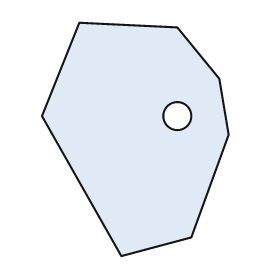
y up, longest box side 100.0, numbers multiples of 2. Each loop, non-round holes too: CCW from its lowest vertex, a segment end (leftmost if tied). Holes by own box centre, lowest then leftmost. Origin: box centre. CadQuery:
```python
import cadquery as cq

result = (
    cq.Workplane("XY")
    .moveTo(-6.0, -50.0)
    .lineTo(24.0, -42.0)
    .lineTo(40.0, 2.0)
    .lineTo(36.0, 26.0)
    .lineTo(18.0, 48.0)
    .lineTo(-24.0, 50.0)
    .lineTo(-40.0, 10.0)
    .close()
    .moveTo(18.0, 10.0)
    .circle(6.0)
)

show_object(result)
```